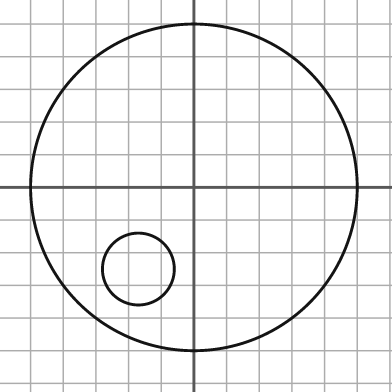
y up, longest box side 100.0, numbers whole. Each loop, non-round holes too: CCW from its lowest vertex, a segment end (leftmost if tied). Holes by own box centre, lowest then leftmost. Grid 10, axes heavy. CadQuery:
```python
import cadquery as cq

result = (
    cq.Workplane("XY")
    .moveTo(0.0, 0.0)
    .circle(50.0)
    .moveTo(-17.0, -25.0)
    .circle(11.0)
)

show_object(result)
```